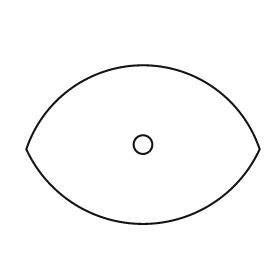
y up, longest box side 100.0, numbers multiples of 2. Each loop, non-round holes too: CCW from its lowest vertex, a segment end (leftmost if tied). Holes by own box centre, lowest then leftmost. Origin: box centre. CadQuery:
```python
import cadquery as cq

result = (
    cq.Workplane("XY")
    .moveTo(-50.0, -2.0)
    .threePointArc((0.0, -34.0), (50.0, -2.0))
    .threePointArc((0.0, 34.0), (-50.0, -2.0))
    .close()
    .moveTo(0.0, 0.0)
    .circle(4.0)
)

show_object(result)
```